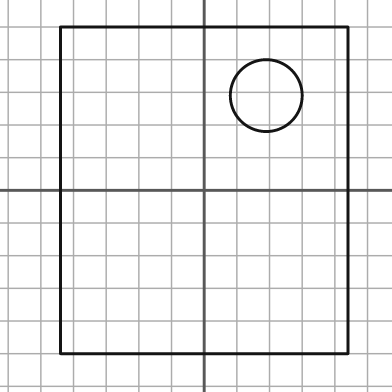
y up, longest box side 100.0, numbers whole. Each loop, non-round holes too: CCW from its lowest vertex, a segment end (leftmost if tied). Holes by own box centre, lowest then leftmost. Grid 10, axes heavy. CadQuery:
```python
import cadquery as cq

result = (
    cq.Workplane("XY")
    .moveTo(-44.0, -50.0)
    .lineTo(44.0, -50.0)
    .lineTo(44.0, 50.0)
    .lineTo(-44.0, 50.0)
    .close()
    .moveTo(19.0, 29.0)
    .circle(11.0)
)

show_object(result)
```